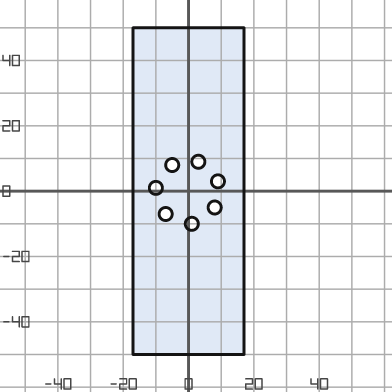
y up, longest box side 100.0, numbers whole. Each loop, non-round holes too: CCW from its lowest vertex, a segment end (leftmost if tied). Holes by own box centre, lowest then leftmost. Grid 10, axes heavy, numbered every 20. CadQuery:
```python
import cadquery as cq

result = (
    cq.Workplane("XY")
    .moveTo(-17.0, -50.0)
    .lineTo(17.0, -50.0)
    .lineTo(17.0, 50.0)
    .lineTo(-17.0, 50.0)
    .close()
    .moveTo(1.0, -10.0)
    .circle(2.0)
    .moveTo(-7.0, -7.0)
    .circle(2.0)
    .moveTo(8.0, -5.0)
    .circle(2.0)
    .moveTo(-10.0, 1.0)
    .circle(2.0)
    .moveTo(9.0, 3.0)
    .circle(2.0)
    .moveTo(-5.0, 8.0)
    .circle(2.0)
    .moveTo(3.0, 9.0)
    .circle(2.0)
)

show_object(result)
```